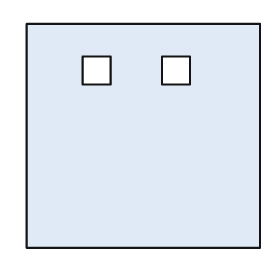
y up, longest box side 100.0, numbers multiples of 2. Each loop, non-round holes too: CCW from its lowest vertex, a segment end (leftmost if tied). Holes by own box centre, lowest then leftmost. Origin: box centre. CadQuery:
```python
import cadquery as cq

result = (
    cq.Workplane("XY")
    .moveTo(-50.0, -48.0)
    .lineTo(50.0, -48.0)
    .lineTo(50.0, 48.0)
    .lineTo(-50.0, 48.0)
    .close()
    .moveTo(-26.0, 22.0)
    .lineTo(-14.0, 22.0)
    .lineTo(-14.0, 34.0)
    .lineTo(-26.0, 34.0)
    .close()
    .moveTo(8.0, 22.0)
    .lineTo(20.0, 22.0)
    .lineTo(20.0, 34.0)
    .lineTo(8.0, 34.0)
    .close()
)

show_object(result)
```